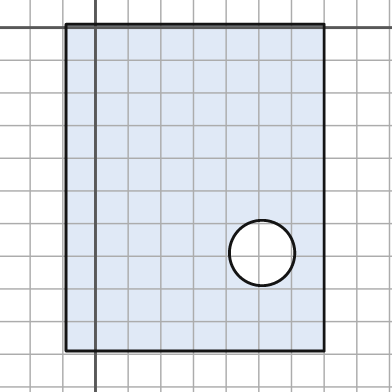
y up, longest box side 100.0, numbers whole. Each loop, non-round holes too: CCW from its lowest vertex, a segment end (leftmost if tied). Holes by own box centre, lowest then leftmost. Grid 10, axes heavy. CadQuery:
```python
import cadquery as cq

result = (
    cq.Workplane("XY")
    .moveTo(-9.0, -99.0)
    .lineTo(70.0, -99.0)
    .lineTo(70.0, 1.0)
    .lineTo(-9.0, 1.0)
    .close()
    .moveTo(51.0, -69.0)
    .circle(10.0)
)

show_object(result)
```